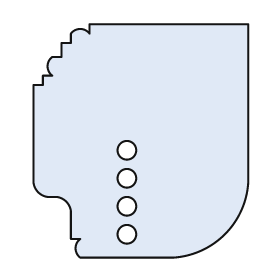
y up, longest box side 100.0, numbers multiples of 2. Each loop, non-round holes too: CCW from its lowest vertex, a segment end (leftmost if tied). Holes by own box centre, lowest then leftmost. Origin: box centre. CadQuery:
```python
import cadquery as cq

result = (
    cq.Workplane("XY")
    .moveTo(-26.0, -50.0)
    .lineTo(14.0, -50.0)
    .threePointArc((36.0, -40.0), (46.0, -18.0))
    .lineTo(46.0, 50.0)
    .lineTo(-22.0, 50.0)
    .lineTo(-22.0, 46.0)
    .threePointArc((-26.0, 48.0), (-30.0, 46.0))
    .lineTo(-30.0, 42.0)
    .lineTo(-34.0, 42.0)
    .lineTo(-34.0, 36.0)
    .lineTo(-38.0, 36.0)
    .threePointArc((-40.0, 32.0), (-38.0, 28.0))
    .lineTo(-42.0, 28.0)
    .lineTo(-42.0, 24.0)
    .lineTo(-46.0, 24.0)
    .lineTo(-46.0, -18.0)
    .threePointArc((-44.0, -22.0), (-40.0, -24.0))
    .lineTo(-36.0, -24.0)
    .threePointArc((-32.0, -26.0), (-30.0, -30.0))
    .lineTo(-30.0, -42.0)
    .lineTo(-26.0, -42.0)
    .threePointArc((-28.0, -46.0), (-26.0, -50.0))
    .close()
    .moveTo(-6.0, -40.0)
    .circle(4.0)
    .moveTo(-6.0, -28.0)
    .circle(4.0)
    .moveTo(-6.0, -16.0)
    .circle(4.0)
    .moveTo(-6.0, -4.0)
    .circle(4.0)
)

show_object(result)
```